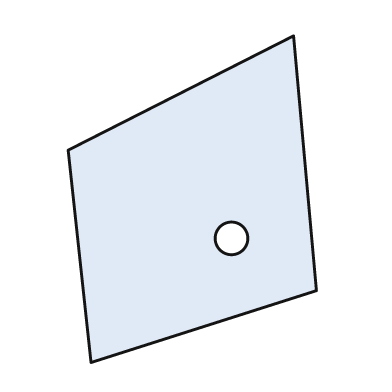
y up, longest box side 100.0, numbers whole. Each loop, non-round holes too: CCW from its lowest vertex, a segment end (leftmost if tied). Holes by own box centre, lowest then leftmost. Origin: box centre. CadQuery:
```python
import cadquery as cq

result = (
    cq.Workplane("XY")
    .moveTo(-31.0, -50.0)
    .lineTo(38.0, -28.0)
    .lineTo(31.0, 50.0)
    .lineTo(-38.0, 15.0)
    .close()
    .moveTo(12.0, -12.0)
    .circle(5.0)
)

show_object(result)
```